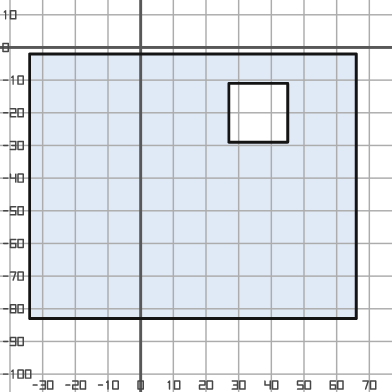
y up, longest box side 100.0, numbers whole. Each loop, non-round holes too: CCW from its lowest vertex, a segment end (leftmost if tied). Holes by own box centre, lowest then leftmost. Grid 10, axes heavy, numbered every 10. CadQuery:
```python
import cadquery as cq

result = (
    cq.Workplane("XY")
    .moveTo(-34.0, -83.0)
    .lineTo(66.0, -83.0)
    .lineTo(66.0, -2.0)
    .lineTo(-34.0, -2.0)
    .close()
    .moveTo(27.0, -29.0)
    .lineTo(45.0, -29.0)
    .lineTo(45.0, -11.0)
    .lineTo(27.0, -11.0)
    .close()
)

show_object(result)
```